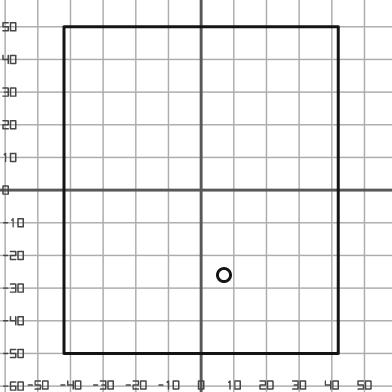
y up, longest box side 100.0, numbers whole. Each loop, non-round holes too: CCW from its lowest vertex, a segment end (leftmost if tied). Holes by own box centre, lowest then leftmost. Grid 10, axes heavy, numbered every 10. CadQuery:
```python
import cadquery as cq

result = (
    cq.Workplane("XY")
    .moveTo(-42.0, -50.0)
    .lineTo(42.0, -50.0)
    .lineTo(42.0, 50.0)
    .lineTo(-42.0, 50.0)
    .close()
    .moveTo(7.0, -26.0)
    .circle(2.0)
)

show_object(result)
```